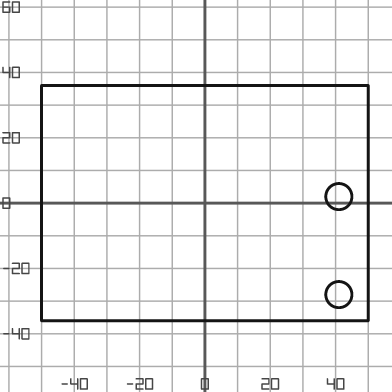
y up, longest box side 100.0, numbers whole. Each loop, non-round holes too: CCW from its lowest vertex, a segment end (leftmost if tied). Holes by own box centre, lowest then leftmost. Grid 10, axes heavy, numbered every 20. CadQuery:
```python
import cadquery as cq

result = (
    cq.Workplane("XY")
    .moveTo(-50.0, -36.0)
    .lineTo(50.0, -36.0)
    .lineTo(50.0, 36.0)
    .lineTo(-50.0, 36.0)
    .close()
    .moveTo(41.0, -28.0)
    .circle(4.0)
    .moveTo(41.0, 2.0)
    .circle(4.0)
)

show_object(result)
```